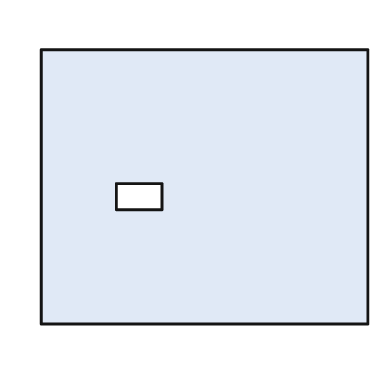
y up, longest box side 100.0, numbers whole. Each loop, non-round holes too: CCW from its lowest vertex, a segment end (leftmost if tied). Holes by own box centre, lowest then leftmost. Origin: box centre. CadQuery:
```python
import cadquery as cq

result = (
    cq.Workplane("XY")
    .moveTo(-50.0, -42.0)
    .lineTo(50.0, -42.0)
    .lineTo(50.0, 42.0)
    .lineTo(-50.0, 42.0)
    .close()
    .moveTo(-27.0, -7.0)
    .lineTo(-13.0, -7.0)
    .lineTo(-13.0, 1.0)
    .lineTo(-27.0, 1.0)
    .close()
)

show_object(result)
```